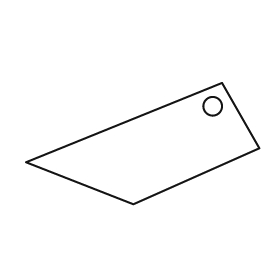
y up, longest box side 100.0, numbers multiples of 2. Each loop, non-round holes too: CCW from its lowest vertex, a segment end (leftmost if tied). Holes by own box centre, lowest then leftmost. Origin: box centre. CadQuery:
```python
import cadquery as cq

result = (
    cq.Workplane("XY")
    .moveTo(-4.0, -26.0)
    .lineTo(50.0, -2.0)
    .lineTo(34.0, 26.0)
    .lineTo(-50.0, -8.0)
    .close()
    .moveTo(30.0, 16.0)
    .circle(4.0)
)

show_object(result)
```